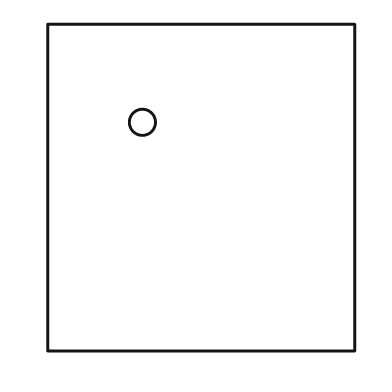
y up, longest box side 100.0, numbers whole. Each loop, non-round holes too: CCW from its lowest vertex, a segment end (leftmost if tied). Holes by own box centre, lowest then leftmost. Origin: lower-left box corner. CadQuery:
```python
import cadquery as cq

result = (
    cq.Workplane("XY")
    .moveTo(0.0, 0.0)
    .lineTo(94.0, 0.0)
    .lineTo(94.0, 100.0)
    .lineTo(0.0, 100.0)
    .close()
    .moveTo(29.0, 70.0)
    .circle(4.0)
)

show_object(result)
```